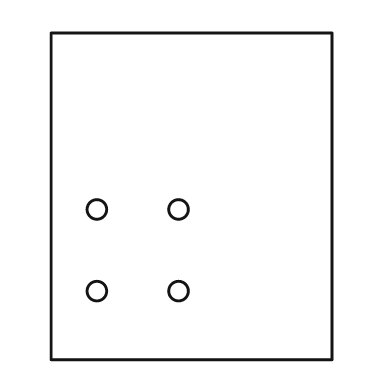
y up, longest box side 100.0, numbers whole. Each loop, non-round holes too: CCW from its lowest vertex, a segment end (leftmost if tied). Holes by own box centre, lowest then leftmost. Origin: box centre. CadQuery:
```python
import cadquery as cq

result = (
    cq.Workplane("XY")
    .moveTo(-43.0, -50.0)
    .lineTo(43.0, -50.0)
    .lineTo(43.0, 50.0)
    .lineTo(-43.0, 50.0)
    .close()
    .moveTo(-29.0, -29.0)
    .circle(3.0)
    .moveTo(-4.0, -29.0)
    .circle(3.0)
    .moveTo(-29.0, -4.0)
    .circle(3.0)
    .moveTo(-4.0, -4.0)
    .circle(3.0)
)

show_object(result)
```